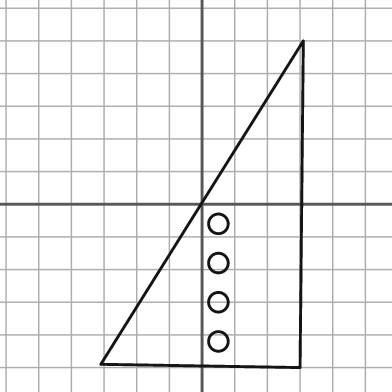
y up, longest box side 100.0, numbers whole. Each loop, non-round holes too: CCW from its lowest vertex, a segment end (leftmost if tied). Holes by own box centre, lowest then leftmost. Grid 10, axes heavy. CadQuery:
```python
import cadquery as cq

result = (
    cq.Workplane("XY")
    .moveTo(30.0, -50.0)
    .lineTo(31.0, 50.0)
    .lineTo(-31.0, -49.0)
    .close()
    .moveTo(5.0, -42.0)
    .circle(3.0)
    .moveTo(5.0, -30.0)
    .circle(3.0)
    .moveTo(5.0, -18.0)
    .circle(3.0)
    .moveTo(5.0, -6.0)
    .circle(3.0)
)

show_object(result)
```